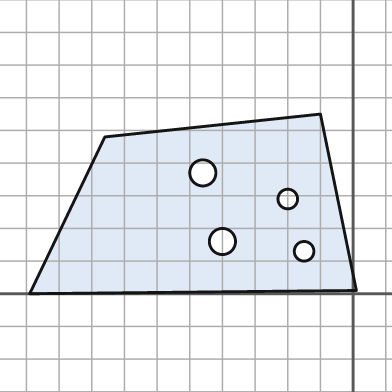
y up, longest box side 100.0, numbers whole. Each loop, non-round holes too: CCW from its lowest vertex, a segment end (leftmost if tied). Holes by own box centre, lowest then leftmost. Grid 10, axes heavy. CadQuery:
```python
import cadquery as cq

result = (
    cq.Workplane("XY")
    .moveTo(-99.0, 0.0)
    .lineTo(1.0, 1.0)
    .lineTo(-10.0, 55.0)
    .lineTo(-76.0, 48.0)
    .close()
    .moveTo(-15.0, 13.0)
    .circle(3.0)
    .moveTo(-40.0, 16.0)
    .circle(4.0)
    .moveTo(-20.0, 29.0)
    .circle(3.0)
    .moveTo(-46.0, 37.0)
    .circle(4.0)
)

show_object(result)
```